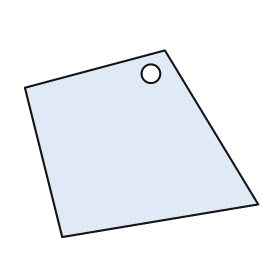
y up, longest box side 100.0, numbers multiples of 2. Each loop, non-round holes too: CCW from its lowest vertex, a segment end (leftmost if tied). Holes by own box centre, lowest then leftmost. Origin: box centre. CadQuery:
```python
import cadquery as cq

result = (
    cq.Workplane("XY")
    .moveTo(-34.0, -40.0)
    .lineTo(50.0, -26.0)
    .lineTo(10.0, 40.0)
    .lineTo(-50.0, 24.0)
    .close()
    .moveTo(4.0, 30.0)
    .circle(4.0)
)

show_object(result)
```